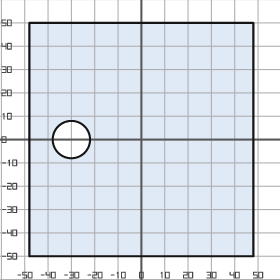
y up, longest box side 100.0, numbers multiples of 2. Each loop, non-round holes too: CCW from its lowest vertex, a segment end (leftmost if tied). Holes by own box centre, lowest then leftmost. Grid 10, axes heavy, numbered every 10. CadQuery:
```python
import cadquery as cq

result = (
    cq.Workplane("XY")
    .moveTo(-48.0, -50.0)
    .lineTo(48.0, -50.0)
    .lineTo(48.0, 50.0)
    .lineTo(-48.0, 50.0)
    .close()
    .moveTo(-30.0, 0.0)
    .circle(8.0)
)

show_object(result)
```